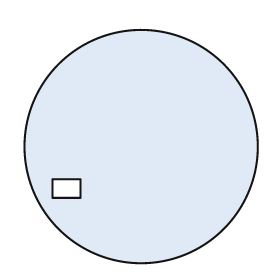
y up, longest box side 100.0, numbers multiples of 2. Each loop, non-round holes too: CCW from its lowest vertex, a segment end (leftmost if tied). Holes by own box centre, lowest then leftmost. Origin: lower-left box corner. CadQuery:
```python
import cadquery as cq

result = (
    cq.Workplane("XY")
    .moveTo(50.0, 50.0)
    .circle(50.0)
    .moveTo(12.0, 28.0)
    .lineTo(24.0, 28.0)
    .lineTo(24.0, 36.0)
    .lineTo(12.0, 36.0)
    .close()
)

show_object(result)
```